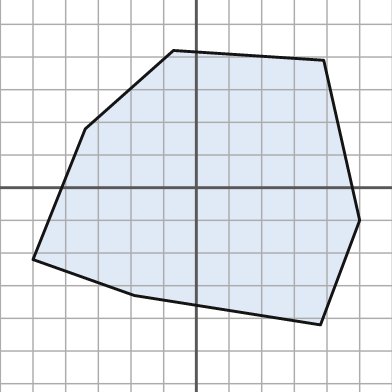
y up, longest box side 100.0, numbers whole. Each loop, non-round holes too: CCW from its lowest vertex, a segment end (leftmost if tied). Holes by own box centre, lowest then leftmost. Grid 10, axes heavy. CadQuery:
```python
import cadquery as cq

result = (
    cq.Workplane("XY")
    .moveTo(38.0, -42.0)
    .lineTo(50.0, -10.0)
    .lineTo(39.0, 39.0)
    .lineTo(-7.0, 42.0)
    .lineTo(-34.0, 18.0)
    .lineTo(-50.0, -22.0)
    .lineTo(-19.0, -33.0)
    .close()
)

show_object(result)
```